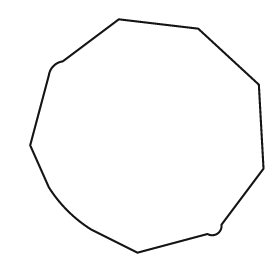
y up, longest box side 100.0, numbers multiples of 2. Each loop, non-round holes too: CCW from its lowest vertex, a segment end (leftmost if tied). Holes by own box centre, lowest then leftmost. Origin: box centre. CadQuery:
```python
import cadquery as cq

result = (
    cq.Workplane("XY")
    .moveTo(-4.0, -50.0)
    .lineTo(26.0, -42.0)
    .threePointArc((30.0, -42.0), (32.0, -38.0))
    .lineTo(50.0, -14.0)
    .lineTo(48.0, 22.0)
    .lineTo(22.0, 46.0)
    .lineTo(-12.0, 50.0)
    .lineTo(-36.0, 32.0)
    .threePointArc((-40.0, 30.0), (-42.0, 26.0))
    .lineTo(-50.0, -4.0)
    .lineTo(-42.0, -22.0)
    .threePointArc((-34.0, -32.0), (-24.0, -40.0))
    .close()
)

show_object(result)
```